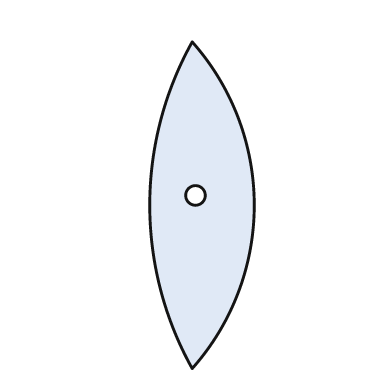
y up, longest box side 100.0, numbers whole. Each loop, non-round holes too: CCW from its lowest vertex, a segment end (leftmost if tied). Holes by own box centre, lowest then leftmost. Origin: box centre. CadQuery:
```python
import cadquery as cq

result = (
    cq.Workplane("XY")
    .moveTo(-3.0, -50.0)
    .threePointArc((16.0, 0.0), (-3.0, 50.0))
    .threePointArc((-16.0, 0.0), (-3.0, -50.0))
    .close()
    .moveTo(-2.0, 3.0)
    .circle(3.0)
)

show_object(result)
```